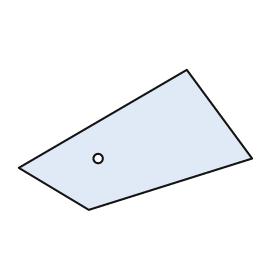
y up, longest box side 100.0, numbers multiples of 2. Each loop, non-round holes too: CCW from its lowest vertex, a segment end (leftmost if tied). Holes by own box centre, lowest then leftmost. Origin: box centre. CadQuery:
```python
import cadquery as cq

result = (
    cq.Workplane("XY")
    .moveTo(-20.0, -30.0)
    .lineTo(50.0, -8.0)
    .lineTo(22.0, 30.0)
    .lineTo(-50.0, -12.0)
    .close()
    .moveTo(-16.0, -8.0)
    .circle(2.0)
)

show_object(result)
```